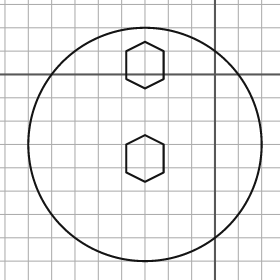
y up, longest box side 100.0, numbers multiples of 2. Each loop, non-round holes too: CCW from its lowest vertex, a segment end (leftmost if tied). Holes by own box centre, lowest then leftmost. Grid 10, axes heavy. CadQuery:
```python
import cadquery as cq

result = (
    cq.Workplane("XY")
    .moveTo(-30.0, -30.0)
    .circle(50.0)
    .moveTo(-30.0, -46.0)
    .lineTo(-22.0, -42.0)
    .lineTo(-22.0, -30.0)
    .lineTo(-30.0, -26.0)
    .lineTo(-38.0, -30.0)
    .lineTo(-38.0, -42.0)
    .close()
    .moveTo(-30.0, -6.0)
    .lineTo(-22.0, -2.0)
    .lineTo(-22.0, 10.0)
    .lineTo(-30.0, 14.0)
    .lineTo(-38.0, 10.0)
    .lineTo(-38.0, -2.0)
    .close()
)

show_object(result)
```